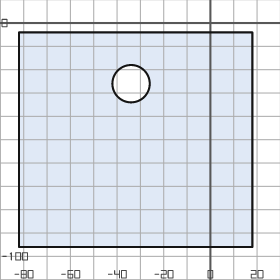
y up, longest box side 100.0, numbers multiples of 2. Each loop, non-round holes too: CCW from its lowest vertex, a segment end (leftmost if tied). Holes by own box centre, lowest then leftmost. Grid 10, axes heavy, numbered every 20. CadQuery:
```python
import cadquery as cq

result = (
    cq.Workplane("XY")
    .moveTo(-82.0, -96.0)
    .lineTo(18.0, -96.0)
    .lineTo(18.0, -4.0)
    .lineTo(-82.0, -4.0)
    .close()
    .moveTo(-34.0, -26.0)
    .circle(8.0)
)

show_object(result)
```